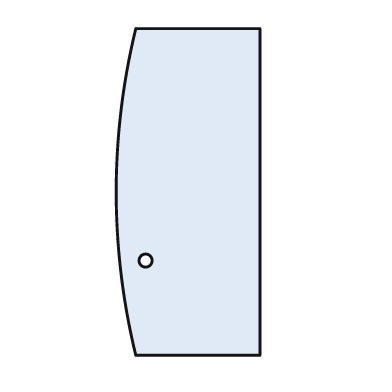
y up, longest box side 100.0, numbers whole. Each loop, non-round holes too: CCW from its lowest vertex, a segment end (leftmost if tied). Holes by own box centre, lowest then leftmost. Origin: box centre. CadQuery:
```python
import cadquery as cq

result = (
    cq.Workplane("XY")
    .moveTo(-16.0, -50.0)
    .lineTo(22.0, -50.0)
    .lineTo(22.0, 50.0)
    .lineTo(-16.0, 50.0)
    .threePointArc((-22.0, 0.0), (-16.0, -50.0))
    .close()
    .moveTo(-13.0, -21.0)
    .circle(2.0)
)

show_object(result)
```